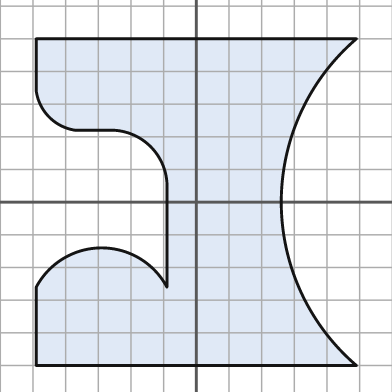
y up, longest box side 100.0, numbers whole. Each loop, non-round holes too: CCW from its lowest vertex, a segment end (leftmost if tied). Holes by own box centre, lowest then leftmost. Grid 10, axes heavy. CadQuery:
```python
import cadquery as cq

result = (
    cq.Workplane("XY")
    .moveTo(-49.0, -50.0)
    .lineTo(49.0, -50.0)
    .threePointArc((26.0, 0.0), (49.0, 50.0))
    .lineTo(-49.0, 50.0)
    .lineTo(-49.0, 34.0)
    .threePointArc((-45.0, 26.0), (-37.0, 22.0))
    .lineTo(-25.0, 22.0)
    .threePointArc((-14.0, 17.0), (-9.0, 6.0))
    .lineTo(-9.0, -26.0)
    .threePointArc((-29.0, -14.0), (-49.0, -26.0))
    .close()
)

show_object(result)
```